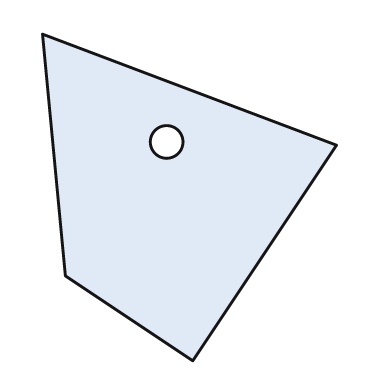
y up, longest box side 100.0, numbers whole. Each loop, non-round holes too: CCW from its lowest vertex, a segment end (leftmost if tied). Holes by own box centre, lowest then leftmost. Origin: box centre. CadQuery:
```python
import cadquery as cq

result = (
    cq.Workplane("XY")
    .moveTo(1.0, -50.0)
    .lineTo(45.0, 16.0)
    .lineTo(-45.0, 50.0)
    .lineTo(-38.0, -24.0)
    .close()
    .moveTo(-7.0, 17.0)
    .circle(5.0)
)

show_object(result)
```